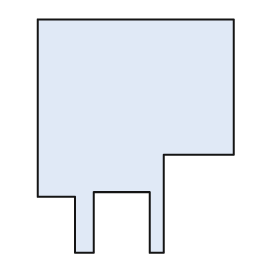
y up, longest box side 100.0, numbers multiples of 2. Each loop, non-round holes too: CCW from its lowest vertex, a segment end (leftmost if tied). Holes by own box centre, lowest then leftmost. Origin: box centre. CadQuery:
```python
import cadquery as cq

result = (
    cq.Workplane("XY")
    .moveTo(-26.0, -50.0)
    .lineTo(-18.0, -50.0)
    .lineTo(-18.0, -24.0)
    .lineTo(6.0, -24.0)
    .lineTo(6.0, -50.0)
    .lineTo(12.0, -50.0)
    .lineTo(12.0, -8.0)
    .lineTo(42.0, -8.0)
    .lineTo(42.0, 50.0)
    .lineTo(-42.0, 50.0)
    .lineTo(-42.0, -26.0)
    .lineTo(-26.0, -26.0)
    .close()
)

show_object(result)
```